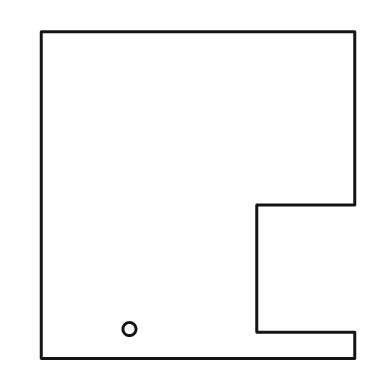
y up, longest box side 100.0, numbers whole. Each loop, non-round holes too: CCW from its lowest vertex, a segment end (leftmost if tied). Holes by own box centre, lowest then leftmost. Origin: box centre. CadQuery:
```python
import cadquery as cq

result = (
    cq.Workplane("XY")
    .moveTo(-48.0, -50.0)
    .lineTo(48.0, -50.0)
    .lineTo(48.0, -42.0)
    .lineTo(18.0, -42.0)
    .lineTo(18.0, -3.0)
    .lineTo(48.0, -3.0)
    .lineTo(48.0, 50.0)
    .lineTo(-48.0, 50.0)
    .close()
    .moveTo(-21.0, -41.0)
    .circle(2.0)
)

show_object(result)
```